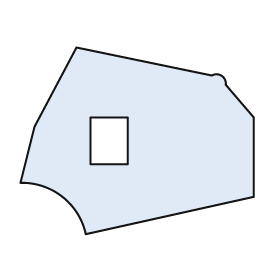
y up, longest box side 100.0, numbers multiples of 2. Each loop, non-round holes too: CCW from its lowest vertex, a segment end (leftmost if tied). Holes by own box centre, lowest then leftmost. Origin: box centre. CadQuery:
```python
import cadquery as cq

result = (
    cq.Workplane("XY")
    .moveTo(-22.0, -40.0)
    .lineTo(50.0, -24.0)
    .lineTo(50.0, 10.0)
    .lineTo(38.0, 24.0)
    .threePointArc((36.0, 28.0), (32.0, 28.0))
    .lineTo(-26.0, 40.0)
    .lineTo(-44.0, 6.0)
    .lineTo(-50.0, -18.0)
    .threePointArc((-32.0, -24.0), (-22.0, -40.0))
    .close()
    .moveTo(-20.0, -10.0)
    .lineTo(-4.0, -10.0)
    .lineTo(-4.0, 10.0)
    .lineTo(-20.0, 10.0)
    .close()
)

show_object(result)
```